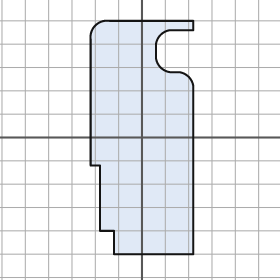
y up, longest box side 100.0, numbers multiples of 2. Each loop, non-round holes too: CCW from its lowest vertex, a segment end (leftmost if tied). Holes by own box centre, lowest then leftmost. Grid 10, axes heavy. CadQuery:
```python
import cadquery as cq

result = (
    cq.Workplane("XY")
    .moveTo(-12.0, -50.0)
    .lineTo(22.0, -50.0)
    .lineTo(22.0, 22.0)
    .threePointArc((20.0, 26.0), (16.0, 28.0))
    .lineTo(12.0, 28.0)
    .threePointArc((8.0, 30.0), (6.0, 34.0))
    .lineTo(6.0, 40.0)
    .threePointArc((8.0, 44.0), (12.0, 46.0))
    .lineTo(22.0, 46.0)
    .lineTo(22.0, 50.0)
    .lineTo(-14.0, 50.0)
    .threePointArc((-20.0, 48.0), (-22.0, 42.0))
    .lineTo(-22.0, -12.0)
    .lineTo(-18.0, -12.0)
    .lineTo(-18.0, -40.0)
    .lineTo(-12.0, -40.0)
    .close()
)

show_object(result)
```